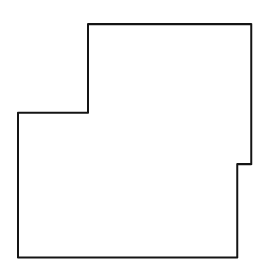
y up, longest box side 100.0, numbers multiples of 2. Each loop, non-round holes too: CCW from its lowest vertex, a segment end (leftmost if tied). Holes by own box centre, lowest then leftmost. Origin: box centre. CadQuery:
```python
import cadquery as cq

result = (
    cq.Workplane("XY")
    .moveTo(-50.0, -50.0)
    .lineTo(44.0, -50.0)
    .lineTo(44.0, -10.0)
    .lineTo(50.0, -10.0)
    .lineTo(50.0, 50.0)
    .lineTo(-20.0, 50.0)
    .lineTo(-20.0, 12.0)
    .lineTo(-50.0, 12.0)
    .close()
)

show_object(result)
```